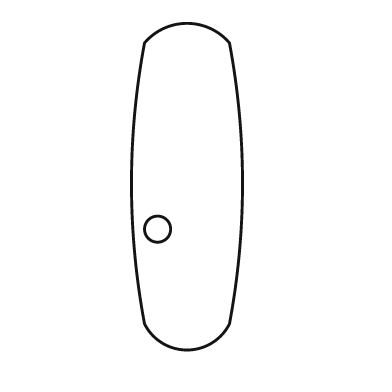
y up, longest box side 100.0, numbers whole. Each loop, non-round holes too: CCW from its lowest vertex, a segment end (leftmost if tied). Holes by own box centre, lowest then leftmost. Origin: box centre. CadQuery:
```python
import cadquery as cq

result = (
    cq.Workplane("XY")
    .moveTo(-13.0, -42.0)
    .threePointArc((0.0, -50.0), (13.0, -42.0))
    .threePointArc((17.0, 1.0), (13.0, 44.0))
    .threePointArc((0.0, 50.0), (-13.0, 44.0))
    .threePointArc((-17.0, 1.0), (-13.0, -42.0))
    .close()
    .moveTo(-9.0, -13.0)
    .circle(4.0)
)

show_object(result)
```